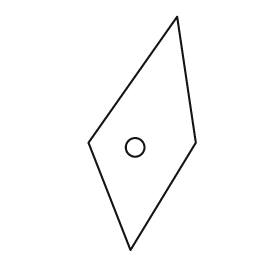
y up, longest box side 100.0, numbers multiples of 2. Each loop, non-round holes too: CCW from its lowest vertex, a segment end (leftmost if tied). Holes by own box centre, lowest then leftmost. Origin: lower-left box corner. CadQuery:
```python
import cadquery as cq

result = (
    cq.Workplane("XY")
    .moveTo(18.0, 0.0)
    .lineTo(46.0, 46.0)
    .lineTo(38.0, 100.0)
    .lineTo(0.0, 46.0)
    .close()
    .moveTo(20.0, 44.0)
    .circle(4.0)
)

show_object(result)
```